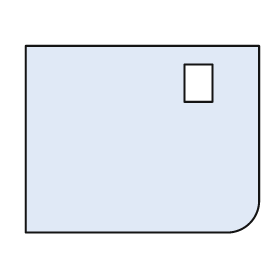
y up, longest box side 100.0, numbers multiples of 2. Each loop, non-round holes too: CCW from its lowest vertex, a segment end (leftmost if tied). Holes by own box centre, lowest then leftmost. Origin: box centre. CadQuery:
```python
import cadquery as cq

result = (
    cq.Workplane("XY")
    .moveTo(-50.0, -40.0)
    .lineTo(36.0, -40.0)
    .threePointArc((46.0, -36.0), (50.0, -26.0))
    .lineTo(50.0, 40.0)
    .lineTo(-50.0, 40.0)
    .close()
    .moveTo(18.0, 16.0)
    .lineTo(30.0, 16.0)
    .lineTo(30.0, 32.0)
    .lineTo(18.0, 32.0)
    .close()
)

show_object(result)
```